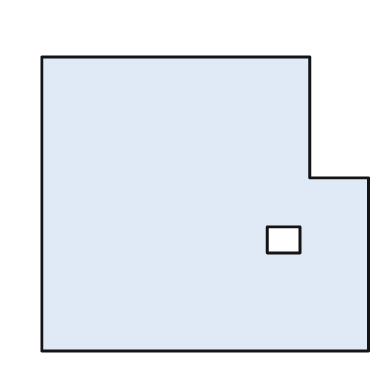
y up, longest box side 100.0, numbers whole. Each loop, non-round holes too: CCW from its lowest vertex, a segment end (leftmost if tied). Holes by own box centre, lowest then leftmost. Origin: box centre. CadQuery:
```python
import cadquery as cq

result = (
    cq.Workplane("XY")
    .moveTo(-50.0, -45.0)
    .lineTo(50.0, -45.0)
    .lineTo(50.0, 8.0)
    .lineTo(32.0, 8.0)
    .lineTo(32.0, 45.0)
    .lineTo(-50.0, 45.0)
    .close()
    .moveTo(19.0, -15.0)
    .lineTo(29.0, -15.0)
    .lineTo(29.0, -7.0)
    .lineTo(19.0, -7.0)
    .close()
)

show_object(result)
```